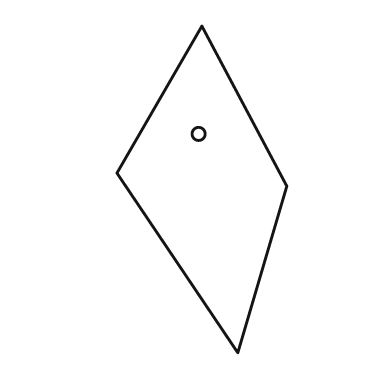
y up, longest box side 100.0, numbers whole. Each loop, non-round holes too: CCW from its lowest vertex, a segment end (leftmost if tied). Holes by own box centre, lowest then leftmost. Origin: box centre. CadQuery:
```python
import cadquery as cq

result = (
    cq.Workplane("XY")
    .moveTo(11.0, -50.0)
    .lineTo(26.0, 1.0)
    .lineTo(0.0, 50.0)
    .lineTo(-26.0, 5.0)
    .close()
    .moveTo(-1.0, 17.0)
    .circle(2.0)
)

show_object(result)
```